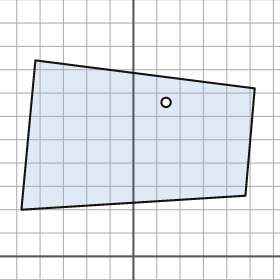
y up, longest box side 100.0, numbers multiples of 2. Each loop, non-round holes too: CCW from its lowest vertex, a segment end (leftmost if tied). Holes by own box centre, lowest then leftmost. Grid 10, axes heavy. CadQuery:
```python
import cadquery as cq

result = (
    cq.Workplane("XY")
    .moveTo(-48.0, 20.0)
    .lineTo(48.0, 26.0)
    .lineTo(52.0, 72.0)
    .lineTo(-42.0, 84.0)
    .close()
    .moveTo(14.0, 66.0)
    .circle(2.0)
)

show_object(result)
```